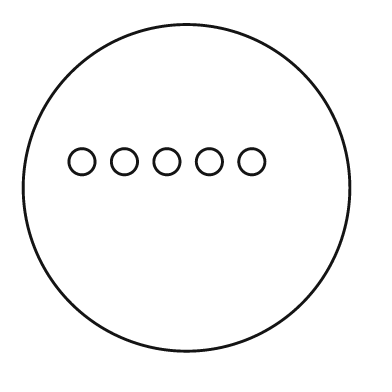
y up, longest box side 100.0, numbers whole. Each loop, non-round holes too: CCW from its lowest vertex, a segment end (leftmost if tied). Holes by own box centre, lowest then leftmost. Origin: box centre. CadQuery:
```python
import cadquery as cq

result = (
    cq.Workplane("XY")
    .moveTo(0.0, 0.0)
    .circle(50.0)
    .moveTo(-32.0, 8.0)
    .circle(4.0)
    .moveTo(-19.0, 8.0)
    .circle(4.0)
    .moveTo(-6.0, 8.0)
    .circle(4.0)
    .moveTo(7.0, 8.0)
    .circle(4.0)
    .moveTo(20.0, 8.0)
    .circle(4.0)
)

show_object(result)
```